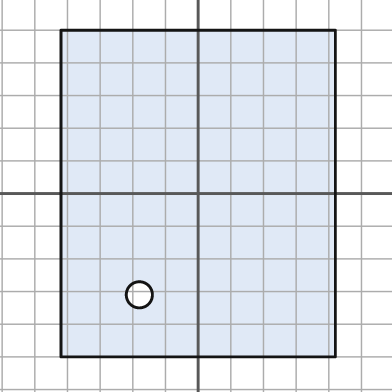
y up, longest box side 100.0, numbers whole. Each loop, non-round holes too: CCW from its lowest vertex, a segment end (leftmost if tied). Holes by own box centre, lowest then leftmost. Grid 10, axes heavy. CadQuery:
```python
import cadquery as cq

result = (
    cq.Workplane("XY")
    .moveTo(-42.0, -50.0)
    .lineTo(42.0, -50.0)
    .lineTo(42.0, 50.0)
    .lineTo(-42.0, 50.0)
    .close()
    .moveTo(-18.0, -31.0)
    .circle(4.0)
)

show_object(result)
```